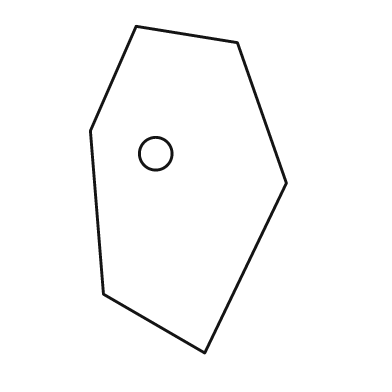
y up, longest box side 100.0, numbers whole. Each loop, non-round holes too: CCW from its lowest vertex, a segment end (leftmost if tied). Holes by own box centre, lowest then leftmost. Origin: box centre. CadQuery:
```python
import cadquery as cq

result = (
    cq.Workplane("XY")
    .moveTo(5.0, -50.0)
    .lineTo(30.0, 2.0)
    .lineTo(15.0, 45.0)
    .lineTo(-16.0, 50.0)
    .lineTo(-30.0, 18.0)
    .lineTo(-26.0, -32.0)
    .close()
    .moveTo(-10.0, 11.0)
    .circle(5.0)
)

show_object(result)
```